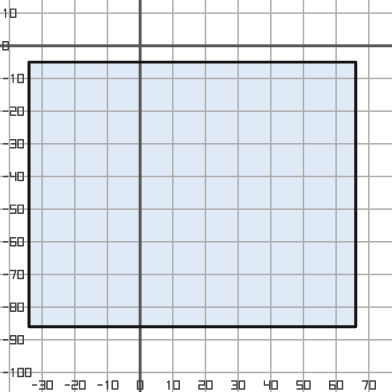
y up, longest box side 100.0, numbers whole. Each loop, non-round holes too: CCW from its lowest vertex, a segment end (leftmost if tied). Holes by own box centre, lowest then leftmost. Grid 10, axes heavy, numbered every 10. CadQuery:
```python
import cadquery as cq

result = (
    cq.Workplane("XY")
    .moveTo(-34.0, -86.0)
    .lineTo(66.0, -86.0)
    .lineTo(66.0, -5.0)
    .lineTo(-34.0, -5.0)
    .close()
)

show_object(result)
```